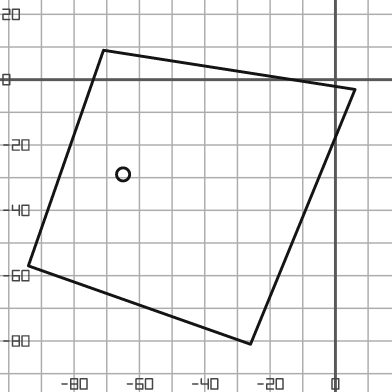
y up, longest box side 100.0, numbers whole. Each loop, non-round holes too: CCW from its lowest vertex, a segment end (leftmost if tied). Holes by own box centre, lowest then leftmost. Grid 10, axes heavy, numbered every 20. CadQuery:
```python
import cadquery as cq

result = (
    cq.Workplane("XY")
    .moveTo(-26.0, -81.0)
    .lineTo(6.0, -3.0)
    .lineTo(-71.0, 9.0)
    .lineTo(-94.0, -57.0)
    .close()
    .moveTo(-65.0, -29.0)
    .circle(2.0)
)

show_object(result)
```